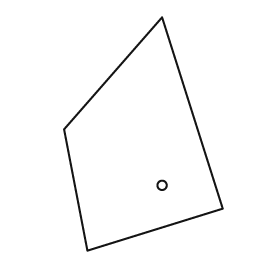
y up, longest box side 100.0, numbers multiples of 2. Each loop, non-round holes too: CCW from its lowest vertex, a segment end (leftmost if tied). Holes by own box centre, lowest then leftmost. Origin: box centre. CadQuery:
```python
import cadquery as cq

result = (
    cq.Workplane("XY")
    .moveTo(-24.0, -50.0)
    .lineTo(34.0, -32.0)
    .lineTo(8.0, 50.0)
    .lineTo(-34.0, 2.0)
    .close()
    .moveTo(8.0, -22.0)
    .circle(2.0)
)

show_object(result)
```